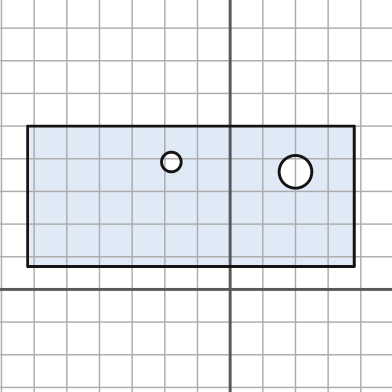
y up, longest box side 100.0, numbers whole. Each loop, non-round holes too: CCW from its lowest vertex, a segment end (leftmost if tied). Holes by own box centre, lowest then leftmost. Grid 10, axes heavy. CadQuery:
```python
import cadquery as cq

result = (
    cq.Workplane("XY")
    .moveTo(-62.0, 7.0)
    .lineTo(38.0, 7.0)
    .lineTo(38.0, 50.0)
    .lineTo(-62.0, 50.0)
    .close()
    .moveTo(20.0, 36.0)
    .circle(5.0)
    .moveTo(-18.0, 39.0)
    .circle(3.0)
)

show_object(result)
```